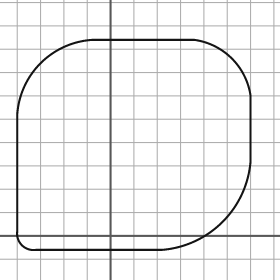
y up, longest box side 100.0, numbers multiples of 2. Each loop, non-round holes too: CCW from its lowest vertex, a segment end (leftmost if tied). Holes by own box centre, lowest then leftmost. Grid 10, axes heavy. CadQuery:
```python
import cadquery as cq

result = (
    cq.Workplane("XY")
    .moveTo(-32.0, -6.0)
    .lineTo(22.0, -6.0)
    .threePointArc((48.0, 6.0), (60.0, 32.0))
    .lineTo(60.0, 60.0)
    .threePointArc((52.0, 76.0), (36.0, 84.0))
    .lineTo(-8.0, 84.0)
    .threePointArc((-30.0, 74.0), (-40.0, 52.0))
    .lineTo(-40.0, 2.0)
    .threePointArc((-38.0, -4.0), (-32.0, -6.0))
    .close()
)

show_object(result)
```